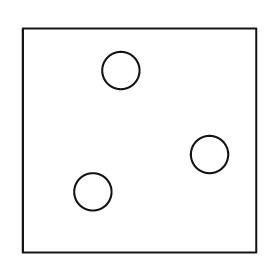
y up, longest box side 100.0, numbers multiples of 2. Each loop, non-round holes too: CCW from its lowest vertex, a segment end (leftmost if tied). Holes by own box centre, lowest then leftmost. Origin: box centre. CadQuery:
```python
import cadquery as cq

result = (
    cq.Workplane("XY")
    .moveTo(-50.0, -48.0)
    .lineTo(50.0, -48.0)
    .lineTo(50.0, 48.0)
    .lineTo(-50.0, 48.0)
    .close()
    .moveTo(-20.0, -22.0)
    .circle(8.0)
    .moveTo(30.0, -6.0)
    .circle(8.0)
    .moveTo(-8.0, 30.0)
    .circle(8.0)
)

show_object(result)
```